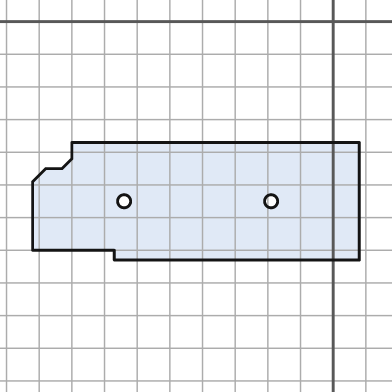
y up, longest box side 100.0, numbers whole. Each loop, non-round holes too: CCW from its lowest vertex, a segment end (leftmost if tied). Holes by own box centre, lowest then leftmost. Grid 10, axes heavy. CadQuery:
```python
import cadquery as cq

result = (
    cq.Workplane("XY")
    .moveTo(-67.0, -73.0)
    .lineTo(8.0, -73.0)
    .lineTo(8.0, -37.0)
    .lineTo(-80.0, -37.0)
    .lineTo(-80.0, -42.0)
    .lineTo(-83.0, -45.0)
    .lineTo(-88.0, -45.0)
    .lineTo(-92.0, -49.0)
    .lineTo(-92.0, -70.0)
    .lineTo(-67.0, -70.0)
    .close()
    .moveTo(-64.0, -55.0)
    .circle(2.0)
    .moveTo(-19.0, -55.0)
    .circle(2.0)
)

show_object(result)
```